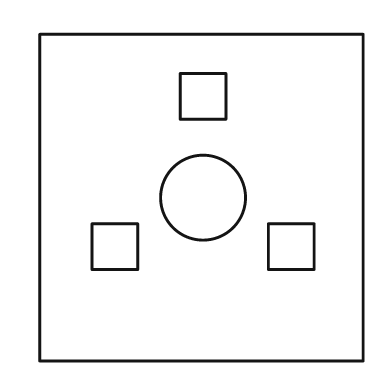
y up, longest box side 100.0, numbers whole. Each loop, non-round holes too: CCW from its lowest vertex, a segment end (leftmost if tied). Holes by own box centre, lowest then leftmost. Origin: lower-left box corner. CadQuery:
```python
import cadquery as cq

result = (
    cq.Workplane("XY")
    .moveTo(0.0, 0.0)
    .lineTo(99.0, 0.0)
    .lineTo(99.0, 100.0)
    .lineTo(0.0, 100.0)
    .close()
    .moveTo(16.0, 28.0)
    .lineTo(30.0, 28.0)
    .lineTo(30.0, 42.0)
    .lineTo(16.0, 42.0)
    .close()
    .moveTo(70.0, 28.0)
    .lineTo(84.0, 28.0)
    .lineTo(84.0, 42.0)
    .lineTo(70.0, 42.0)
    .close()
    .moveTo(50.0, 50.0)
    .circle(13.0)
    .moveTo(43.0, 74.0)
    .lineTo(57.0, 74.0)
    .lineTo(57.0, 88.0)
    .lineTo(43.0, 88.0)
    .close()
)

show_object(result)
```